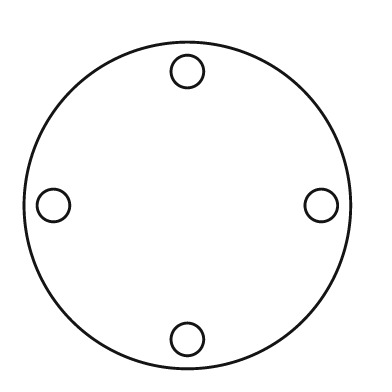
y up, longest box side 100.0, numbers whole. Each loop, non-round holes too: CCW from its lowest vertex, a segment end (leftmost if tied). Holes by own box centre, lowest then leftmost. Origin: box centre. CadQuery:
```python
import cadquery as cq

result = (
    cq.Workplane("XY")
    .moveTo(0.0, 0.0)
    .circle(50.0)
    .moveTo(0.0, -41.0)
    .circle(5.0)
    .moveTo(-41.0, 0.0)
    .circle(5.0)
    .moveTo(41.0, 0.0)
    .circle(5.0)
    .moveTo(0.0, 41.0)
    .circle(5.0)
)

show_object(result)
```